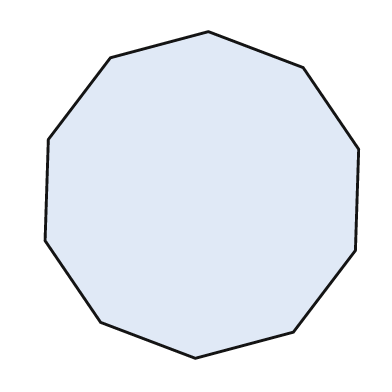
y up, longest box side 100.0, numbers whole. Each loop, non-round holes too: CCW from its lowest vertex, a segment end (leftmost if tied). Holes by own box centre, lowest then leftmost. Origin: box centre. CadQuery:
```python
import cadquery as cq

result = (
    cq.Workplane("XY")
    .moveTo(-2.0, -50.0)
    .lineTo(28.0, -42.0)
    .lineTo(47.0, -17.0)
    .lineTo(48.0, 14.0)
    .lineTo(31.0, 39.0)
    .lineTo(2.0, 50.0)
    .lineTo(-28.0, 42.0)
    .lineTo(-47.0, 17.0)
    .lineTo(-48.0, -14.0)
    .lineTo(-31.0, -39.0)
    .close()
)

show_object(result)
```